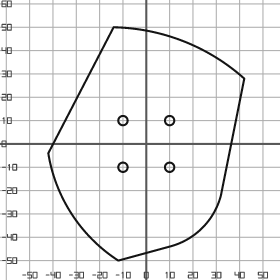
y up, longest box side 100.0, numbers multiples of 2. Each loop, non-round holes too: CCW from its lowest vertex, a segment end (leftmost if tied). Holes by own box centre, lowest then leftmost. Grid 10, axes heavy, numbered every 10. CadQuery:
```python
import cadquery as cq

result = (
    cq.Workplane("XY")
    .moveTo(-12.0, -50.0)
    .lineTo(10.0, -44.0)
    .threePointArc((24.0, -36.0), (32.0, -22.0))
    .lineTo(42.0, 28.0)
    .threePointArc((16.0, 44.0), (-14.0, 50.0))
    .lineTo(-42.0, -4.0)
    .threePointArc((-32.0, -30.0), (-12.0, -50.0))
    .close()
    .moveTo(-10.0, -10.0)
    .circle(2.0)
    .moveTo(10.0, -10.0)
    .circle(2.0)
    .moveTo(-10.0, 10.0)
    .circle(2.0)
    .moveTo(10.0, 10.0)
    .circle(2.0)
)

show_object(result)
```